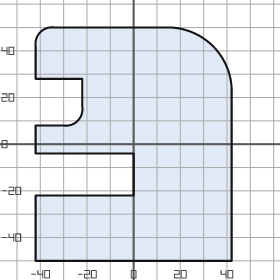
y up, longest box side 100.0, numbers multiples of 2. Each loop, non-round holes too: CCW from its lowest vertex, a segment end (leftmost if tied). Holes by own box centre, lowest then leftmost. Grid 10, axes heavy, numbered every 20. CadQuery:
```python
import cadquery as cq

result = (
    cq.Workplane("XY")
    .moveTo(-42.0, -50.0)
    .lineTo(42.0, -50.0)
    .lineTo(42.0, 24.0)
    .threePointArc((34.0, 42.0), (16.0, 50.0))
    .lineTo(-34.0, 50.0)
    .threePointArc((-40.0, 48.0), (-42.0, 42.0))
    .lineTo(-42.0, 28.0)
    .lineTo(-22.0, 28.0)
    .lineTo(-22.0, 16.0)
    .threePointArc((-24.0, 10.0), (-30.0, 8.0))
    .lineTo(-42.0, 8.0)
    .lineTo(-42.0, -4.0)
    .lineTo(0.0, -4.0)
    .lineTo(0.0, -22.0)
    .lineTo(-42.0, -22.0)
    .close()
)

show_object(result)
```